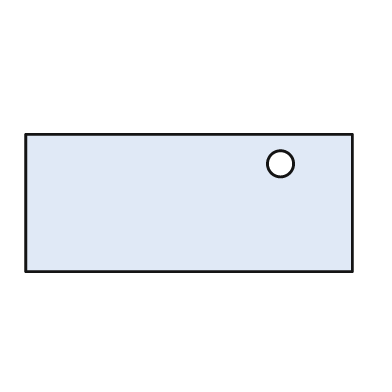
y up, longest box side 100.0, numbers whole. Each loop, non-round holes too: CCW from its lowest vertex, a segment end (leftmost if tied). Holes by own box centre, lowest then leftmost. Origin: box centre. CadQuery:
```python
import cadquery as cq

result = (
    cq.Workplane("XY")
    .moveTo(-50.0, -21.0)
    .lineTo(50.0, -21.0)
    .lineTo(50.0, 21.0)
    .lineTo(-50.0, 21.0)
    .close()
    .moveTo(28.0, 12.0)
    .circle(4.0)
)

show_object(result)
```